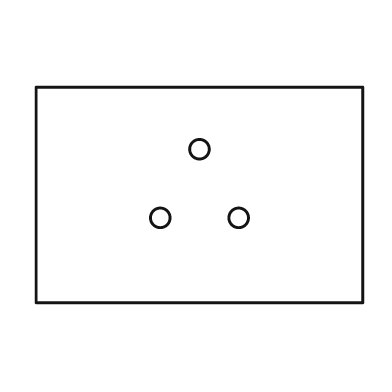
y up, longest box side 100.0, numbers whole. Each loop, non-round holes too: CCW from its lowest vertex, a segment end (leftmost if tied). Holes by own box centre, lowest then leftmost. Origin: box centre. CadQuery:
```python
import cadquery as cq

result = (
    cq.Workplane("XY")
    .moveTo(-50.0, -33.0)
    .lineTo(50.0, -33.0)
    .lineTo(50.0, 33.0)
    .lineTo(-50.0, 33.0)
    .close()
    .moveTo(-12.0, -7.0)
    .circle(3.0)
    .moveTo(12.0, -7.0)
    .circle(3.0)
    .moveTo(0.0, 14.0)
    .circle(3.0)
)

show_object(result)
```